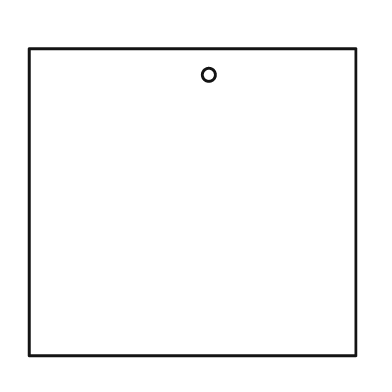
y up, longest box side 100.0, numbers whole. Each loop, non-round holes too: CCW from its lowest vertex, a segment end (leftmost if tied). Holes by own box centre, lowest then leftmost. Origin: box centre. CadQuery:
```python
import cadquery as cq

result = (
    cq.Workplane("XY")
    .moveTo(-50.0, -47.0)
    .lineTo(50.0, -47.0)
    .lineTo(50.0, 47.0)
    .lineTo(-50.0, 47.0)
    .close()
    .moveTo(5.0, 39.0)
    .circle(2.0)
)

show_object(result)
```